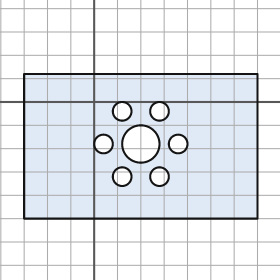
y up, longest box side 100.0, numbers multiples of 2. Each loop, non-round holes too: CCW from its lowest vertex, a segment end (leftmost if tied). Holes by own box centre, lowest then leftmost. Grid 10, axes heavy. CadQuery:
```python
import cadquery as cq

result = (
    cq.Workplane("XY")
    .moveTo(-30.0, -50.0)
    .lineTo(70.0, -50.0)
    .lineTo(70.0, 12.0)
    .lineTo(-30.0, 12.0)
    .close()
    .moveTo(12.0, -32.0)
    .circle(4.0)
    .moveTo(28.0, -32.0)
    .circle(4.0)
    .moveTo(4.0, -18.0)
    .circle(4.0)
    .moveTo(20.0, -18.0)
    .circle(8.0)
    .moveTo(36.0, -18.0)
    .circle(4.0)
    .moveTo(12.0, -4.0)
    .circle(4.0)
    .moveTo(28.0, -4.0)
    .circle(4.0)
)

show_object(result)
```